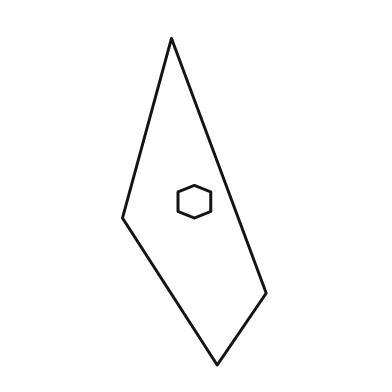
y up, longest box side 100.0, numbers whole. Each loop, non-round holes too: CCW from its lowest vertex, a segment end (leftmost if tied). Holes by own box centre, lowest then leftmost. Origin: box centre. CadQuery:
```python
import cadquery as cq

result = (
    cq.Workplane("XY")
    .moveTo(7.0, -50.0)
    .lineTo(22.0, -28.0)
    .lineTo(-7.0, 50.0)
    .lineTo(-22.0, -5.0)
    .close()
    .moveTo(0.0, -5.0)
    .lineTo(5.0, -3.0)
    .lineTo(5.0, 3.0)
    .lineTo(0.0, 5.0)
    .lineTo(-5.0, 3.0)
    .lineTo(-5.0, -3.0)
    .close()
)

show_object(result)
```